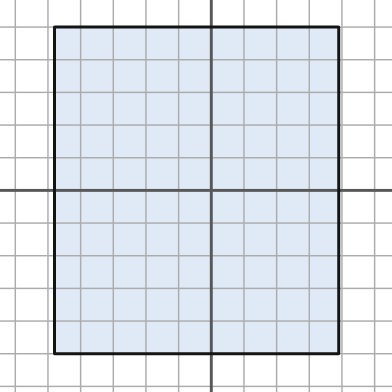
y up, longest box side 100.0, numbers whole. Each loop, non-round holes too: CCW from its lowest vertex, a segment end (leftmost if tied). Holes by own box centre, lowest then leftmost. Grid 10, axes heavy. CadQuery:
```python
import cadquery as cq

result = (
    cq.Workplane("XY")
    .moveTo(-48.0, -50.0)
    .lineTo(39.0, -50.0)
    .lineTo(39.0, 50.0)
    .lineTo(-48.0, 50.0)
    .close()
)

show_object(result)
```